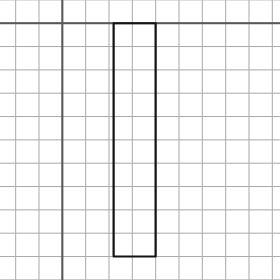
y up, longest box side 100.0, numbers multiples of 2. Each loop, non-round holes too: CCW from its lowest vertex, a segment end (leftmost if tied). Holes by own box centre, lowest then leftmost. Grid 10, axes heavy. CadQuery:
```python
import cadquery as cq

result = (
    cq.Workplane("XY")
    .moveTo(22.0, -100.0)
    .lineTo(40.0, -100.0)
    .lineTo(40.0, 0.0)
    .lineTo(22.0, 0.0)
    .close()
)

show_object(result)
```